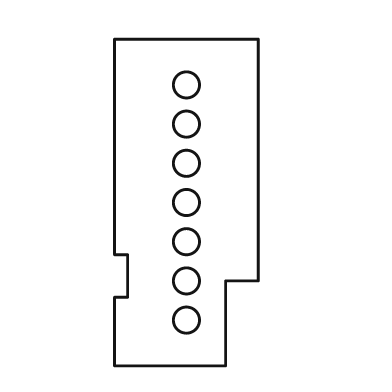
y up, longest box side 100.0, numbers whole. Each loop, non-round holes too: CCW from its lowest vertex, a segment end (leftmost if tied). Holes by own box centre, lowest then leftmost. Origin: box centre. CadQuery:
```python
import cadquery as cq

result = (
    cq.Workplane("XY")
    .moveTo(-22.0, -50.0)
    .lineTo(12.0, -50.0)
    .lineTo(12.0, -24.0)
    .lineTo(22.0, -24.0)
    .lineTo(22.0, 50.0)
    .lineTo(-22.0, 50.0)
    .lineTo(-22.0, -16.0)
    .lineTo(-18.0, -16.0)
    .lineTo(-18.0, -29.0)
    .lineTo(-22.0, -29.0)
    .close()
    .moveTo(0.0, -36.0)
    .circle(4.0)
    .moveTo(0.0, -24.0)
    .circle(4.0)
    .moveTo(0.0, -12.0)
    .circle(4.0)
    .moveTo(0.0, 0.0)
    .circle(4.0)
    .moveTo(0.0, 12.0)
    .circle(4.0)
    .moveTo(0.0, 24.0)
    .circle(4.0)
    .moveTo(0.0, 36.0)
    .circle(4.0)
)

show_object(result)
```